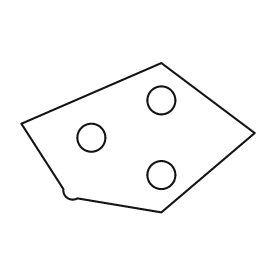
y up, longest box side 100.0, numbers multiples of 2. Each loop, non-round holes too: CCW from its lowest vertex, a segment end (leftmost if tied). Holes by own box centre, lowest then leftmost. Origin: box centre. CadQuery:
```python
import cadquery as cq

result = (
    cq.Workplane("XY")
    .moveTo(10.0, -32.0)
    .lineTo(50.0, 2.0)
    .lineTo(10.0, 32.0)
    .lineTo(-50.0, 6.0)
    .lineTo(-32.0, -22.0)
    .threePointArc((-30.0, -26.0), (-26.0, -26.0))
    .close()
    .moveTo(10.0, -16.0)
    .circle(6.0)
    .moveTo(-20.0, 0.0)
    .circle(6.0)
    .moveTo(10.0, 16.0)
    .circle(6.0)
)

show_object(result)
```